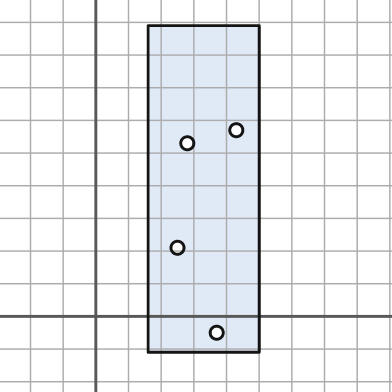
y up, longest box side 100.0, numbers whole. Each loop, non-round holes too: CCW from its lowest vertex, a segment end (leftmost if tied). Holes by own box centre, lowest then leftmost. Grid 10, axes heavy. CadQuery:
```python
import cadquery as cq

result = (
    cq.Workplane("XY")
    .moveTo(16.0, -11.0)
    .lineTo(50.0, -11.0)
    .lineTo(50.0, 89.0)
    .lineTo(16.0, 89.0)
    .close()
    .moveTo(37.0, -5.0)
    .circle(2.0)
    .moveTo(25.0, 21.0)
    .circle(2.0)
    .moveTo(28.0, 53.0)
    .circle(2.0)
    .moveTo(43.0, 57.0)
    .circle(2.0)
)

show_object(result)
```